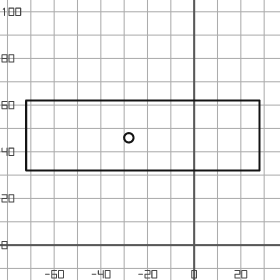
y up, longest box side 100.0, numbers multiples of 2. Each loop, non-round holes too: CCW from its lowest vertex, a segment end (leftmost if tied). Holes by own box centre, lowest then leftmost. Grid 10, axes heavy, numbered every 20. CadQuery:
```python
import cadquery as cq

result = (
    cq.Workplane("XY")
    .moveTo(-72.0, 32.0)
    .lineTo(28.0, 32.0)
    .lineTo(28.0, 62.0)
    .lineTo(-72.0, 62.0)
    .close()
    .moveTo(-28.0, 46.0)
    .circle(2.0)
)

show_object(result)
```